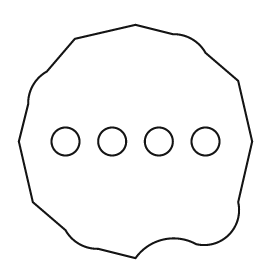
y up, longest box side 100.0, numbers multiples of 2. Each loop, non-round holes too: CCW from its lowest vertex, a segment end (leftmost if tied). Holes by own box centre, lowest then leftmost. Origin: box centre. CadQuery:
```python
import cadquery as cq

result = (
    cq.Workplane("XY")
    .moveTo(0.0, -50.0)
    .threePointArc((12.0, -42.0), (26.0, -44.0))
    .threePointArc((40.0, -40.0), (44.0, -26.0))
    .lineTo(50.0, 0.0)
    .lineTo(44.0, 26.0)
    .lineTo(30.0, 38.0)
    .threePointArc((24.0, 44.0), (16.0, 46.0))
    .lineTo(0.0, 50.0)
    .lineTo(-26.0, 44.0)
    .lineTo(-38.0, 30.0)
    .threePointArc((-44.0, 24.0), (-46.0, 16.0))
    .lineTo(-50.0, 0.0)
    .lineTo(-44.0, -26.0)
    .lineTo(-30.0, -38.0)
    .threePointArc((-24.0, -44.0), (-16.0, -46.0))
    .close()
    .moveTo(-30.0, 0.0)
    .circle(6.0)
    .moveTo(-10.0, 0.0)
    .circle(6.0)
    .moveTo(10.0, 0.0)
    .circle(6.0)
    .moveTo(30.0, 0.0)
    .circle(6.0)
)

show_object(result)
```